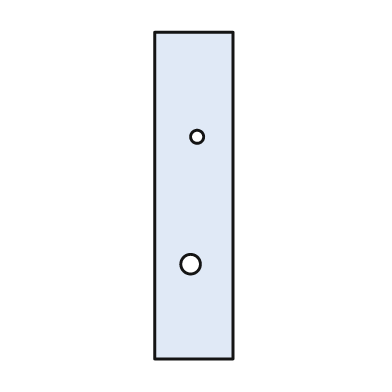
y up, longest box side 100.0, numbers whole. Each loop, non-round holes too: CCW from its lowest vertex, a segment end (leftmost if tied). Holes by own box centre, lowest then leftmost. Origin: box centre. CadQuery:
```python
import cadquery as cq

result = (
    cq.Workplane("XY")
    .moveTo(-12.0, -50.0)
    .lineTo(12.0, -50.0)
    .lineTo(12.0, 50.0)
    .lineTo(-12.0, 50.0)
    .close()
    .moveTo(-1.0, -21.0)
    .circle(3.0)
    .moveTo(1.0, 18.0)
    .circle(2.0)
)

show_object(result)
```